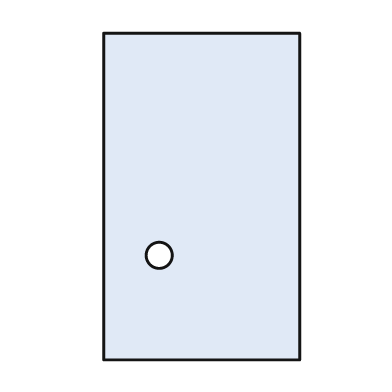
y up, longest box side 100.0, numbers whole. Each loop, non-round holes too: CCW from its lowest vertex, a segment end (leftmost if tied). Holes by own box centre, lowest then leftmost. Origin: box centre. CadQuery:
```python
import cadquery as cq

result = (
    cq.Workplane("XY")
    .moveTo(-30.0, -50.0)
    .lineTo(30.0, -50.0)
    .lineTo(30.0, 50.0)
    .lineTo(-30.0, 50.0)
    .close()
    .moveTo(-13.0, -18.0)
    .circle(4.0)
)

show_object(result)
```